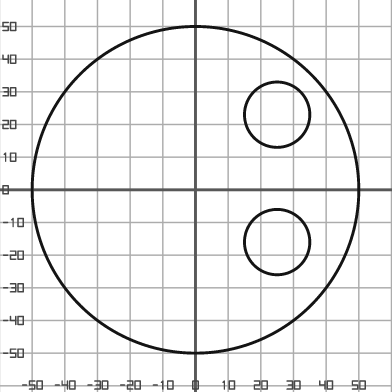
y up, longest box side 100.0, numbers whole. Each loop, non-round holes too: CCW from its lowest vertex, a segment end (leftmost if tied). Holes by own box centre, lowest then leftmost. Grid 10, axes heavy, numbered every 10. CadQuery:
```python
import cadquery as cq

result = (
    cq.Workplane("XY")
    .moveTo(0.0, 0.0)
    .circle(50.0)
    .moveTo(25.0, -16.0)
    .circle(10.0)
    .moveTo(25.0, 23.0)
    .circle(10.0)
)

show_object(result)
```